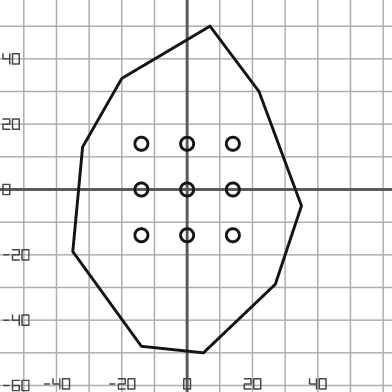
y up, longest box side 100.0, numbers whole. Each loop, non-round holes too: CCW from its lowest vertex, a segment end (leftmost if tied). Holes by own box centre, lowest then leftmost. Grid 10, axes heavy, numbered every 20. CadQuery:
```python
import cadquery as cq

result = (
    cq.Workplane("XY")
    .moveTo(5.0, -50.0)
    .lineTo(27.0, -29.0)
    .lineTo(35.0, -5.0)
    .lineTo(22.0, 30.0)
    .lineTo(7.0, 50.0)
    .lineTo(-20.0, 34.0)
    .lineTo(-32.0, 13.0)
    .lineTo(-35.0, -19.0)
    .lineTo(-14.0, -48.0)
    .close()
    .moveTo(-14.0, -14.0)
    .circle(2.0)
    .moveTo(0.0, -14.0)
    .circle(2.0)
    .moveTo(14.0, -14.0)
    .circle(2.0)
    .moveTo(-14.0, 0.0)
    .circle(2.0)
    .moveTo(0.0, 0.0)
    .circle(2.0)
    .moveTo(14.0, 0.0)
    .circle(2.0)
    .moveTo(-14.0, 14.0)
    .circle(2.0)
    .moveTo(0.0, 14.0)
    .circle(2.0)
    .moveTo(14.0, 14.0)
    .circle(2.0)
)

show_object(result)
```